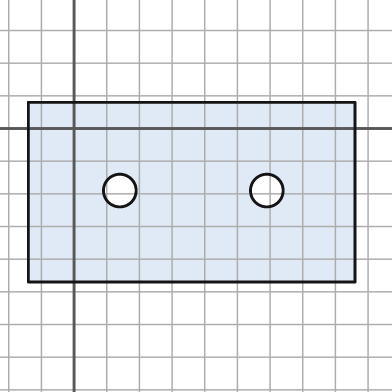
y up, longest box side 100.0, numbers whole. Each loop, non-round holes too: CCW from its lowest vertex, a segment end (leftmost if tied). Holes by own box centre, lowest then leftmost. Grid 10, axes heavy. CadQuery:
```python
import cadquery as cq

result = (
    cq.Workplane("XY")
    .moveTo(-14.0, -47.0)
    .lineTo(86.0, -47.0)
    .lineTo(86.0, 8.0)
    .lineTo(-14.0, 8.0)
    .close()
    .moveTo(14.0, -19.0)
    .circle(5.0)
    .moveTo(59.0, -19.0)
    .circle(5.0)
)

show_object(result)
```